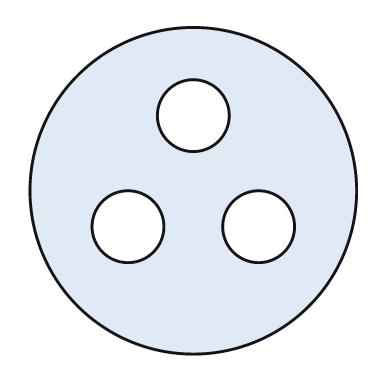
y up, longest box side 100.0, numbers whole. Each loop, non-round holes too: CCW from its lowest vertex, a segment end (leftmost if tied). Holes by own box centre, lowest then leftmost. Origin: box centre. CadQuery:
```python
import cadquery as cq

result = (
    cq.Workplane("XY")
    .moveTo(0.0, 0.0)
    .circle(50.0)
    .moveTo(-20.0, -11.0)
    .circle(11.0)
    .moveTo(20.0, -11.0)
    .circle(11.0)
    .moveTo(0.0, 23.0)
    .circle(11.0)
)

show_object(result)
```